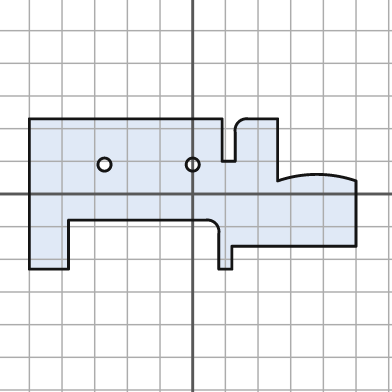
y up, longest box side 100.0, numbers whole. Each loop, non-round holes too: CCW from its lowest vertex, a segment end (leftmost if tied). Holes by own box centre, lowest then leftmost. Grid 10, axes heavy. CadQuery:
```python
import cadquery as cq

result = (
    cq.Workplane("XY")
    .moveTo(-50.0, -23.0)
    .lineTo(-38.0, -23.0)
    .lineTo(-38.0, -8.0)
    .lineTo(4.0, -8.0)
    .threePointArc((7.0, -9.0), (8.0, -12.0))
    .lineTo(8.0, -23.0)
    .lineTo(12.0, -23.0)
    .lineTo(12.0, -16.0)
    .lineTo(50.0, -16.0)
    .lineTo(50.0, 4.0)
    .threePointArc((38.0, 6.0), (26.0, 4.0))
    .lineTo(26.0, 23.0)
    .lineTo(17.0, 23.0)
    .threePointArc((14.0, 22.0), (13.0, 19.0))
    .lineTo(13.0, 10.0)
    .lineTo(9.0, 10.0)
    .lineTo(9.0, 23.0)
    .lineTo(-50.0, 23.0)
    .close()
    .moveTo(-27.0, 9.0)
    .circle(2.0)
    .moveTo(0.0, 9.0)
    .circle(2.0)
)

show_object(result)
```